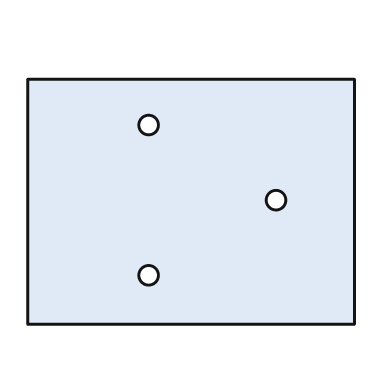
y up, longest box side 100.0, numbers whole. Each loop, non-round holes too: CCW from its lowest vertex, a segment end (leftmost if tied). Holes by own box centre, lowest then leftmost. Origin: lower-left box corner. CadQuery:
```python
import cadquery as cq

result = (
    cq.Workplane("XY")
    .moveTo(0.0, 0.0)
    .lineTo(100.0, 0.0)
    .lineTo(100.0, 75.0)
    .lineTo(0.0, 75.0)
    .close()
    .moveTo(37.0, 15.0)
    .circle(3.0)
    .moveTo(76.0, 38.0)
    .circle(3.0)
    .moveTo(37.0, 61.0)
    .circle(3.0)
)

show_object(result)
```